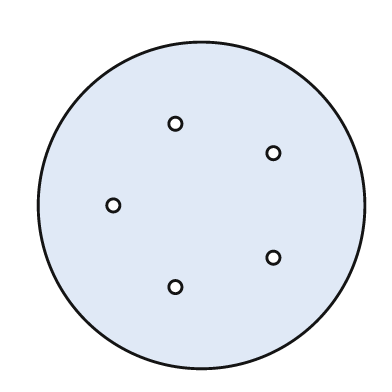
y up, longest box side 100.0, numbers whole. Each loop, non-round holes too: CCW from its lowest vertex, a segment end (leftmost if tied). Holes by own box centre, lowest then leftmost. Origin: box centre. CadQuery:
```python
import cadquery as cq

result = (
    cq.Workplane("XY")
    .moveTo(0.0, 0.0)
    .circle(50.0)
    .moveTo(-8.0, -25.0)
    .circle(2.0)
    .moveTo(22.0, -16.0)
    .circle(2.0)
    .moveTo(-27.0, 0.0)
    .circle(2.0)
    .moveTo(22.0, 16.0)
    .circle(2.0)
    .moveTo(-8.0, 25.0)
    .circle(2.0)
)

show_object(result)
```